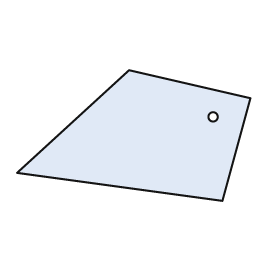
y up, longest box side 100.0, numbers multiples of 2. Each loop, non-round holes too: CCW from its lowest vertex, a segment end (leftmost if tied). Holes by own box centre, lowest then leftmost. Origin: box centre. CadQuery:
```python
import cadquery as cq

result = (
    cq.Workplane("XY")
    .moveTo(38.0, -28.0)
    .lineTo(50.0, 16.0)
    .lineTo(-2.0, 28.0)
    .lineTo(-50.0, -16.0)
    .close()
    .moveTo(34.0, 8.0)
    .circle(2.0)
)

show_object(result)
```